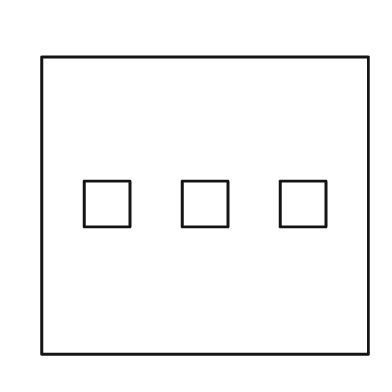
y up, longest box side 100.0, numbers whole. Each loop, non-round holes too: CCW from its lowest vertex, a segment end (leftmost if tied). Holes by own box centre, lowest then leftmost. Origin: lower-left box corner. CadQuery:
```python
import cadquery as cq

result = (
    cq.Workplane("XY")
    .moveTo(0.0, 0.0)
    .lineTo(100.0, 0.0)
    .lineTo(100.0, 91.0)
    .lineTo(0.0, 91.0)
    .close()
    .moveTo(13.0, 39.0)
    .lineTo(27.0, 39.0)
    .lineTo(27.0, 53.0)
    .lineTo(13.0, 53.0)
    .close()
    .moveTo(43.0, 39.0)
    .lineTo(57.0, 39.0)
    .lineTo(57.0, 53.0)
    .lineTo(43.0, 53.0)
    .close()
    .moveTo(73.0, 39.0)
    .lineTo(87.0, 39.0)
    .lineTo(87.0, 53.0)
    .lineTo(73.0, 53.0)
    .close()
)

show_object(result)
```